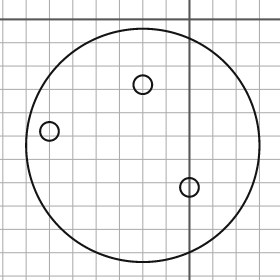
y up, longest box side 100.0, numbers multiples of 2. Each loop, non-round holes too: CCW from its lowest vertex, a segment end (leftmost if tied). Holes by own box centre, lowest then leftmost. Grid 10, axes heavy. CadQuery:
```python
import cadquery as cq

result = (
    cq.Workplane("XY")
    .moveTo(-20.0, -54.0)
    .circle(50.0)
    .moveTo(0.0, -72.0)
    .circle(4.0)
    .moveTo(-60.0, -48.0)
    .circle(4.0)
    .moveTo(-20.0, -28.0)
    .circle(4.0)
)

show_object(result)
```